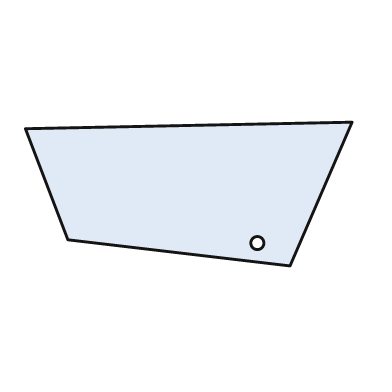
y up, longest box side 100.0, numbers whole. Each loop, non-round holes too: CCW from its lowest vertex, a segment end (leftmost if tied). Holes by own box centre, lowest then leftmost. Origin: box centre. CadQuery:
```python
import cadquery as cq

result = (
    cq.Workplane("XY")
    .moveTo(31.0, -22.0)
    .lineTo(50.0, 22.0)
    .lineTo(-50.0, 20.0)
    .lineTo(-37.0, -14.0)
    .close()
    .moveTo(21.0, -15.0)
    .circle(2.0)
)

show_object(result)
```